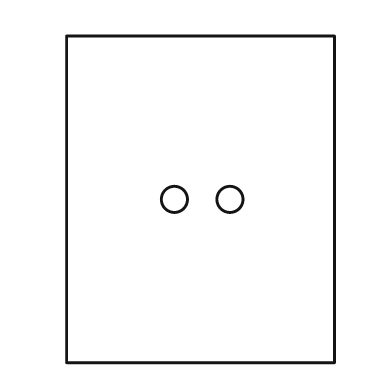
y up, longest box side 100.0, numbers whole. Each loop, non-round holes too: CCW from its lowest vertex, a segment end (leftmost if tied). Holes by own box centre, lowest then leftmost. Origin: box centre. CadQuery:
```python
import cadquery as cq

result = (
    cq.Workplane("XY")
    .moveTo(-41.0, -50.0)
    .lineTo(41.0, -50.0)
    .lineTo(41.0, 50.0)
    .lineTo(-41.0, 50.0)
    .close()
    .moveTo(-8.0, 0.0)
    .circle(4.0)
    .moveTo(9.0, 0.0)
    .circle(4.0)
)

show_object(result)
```